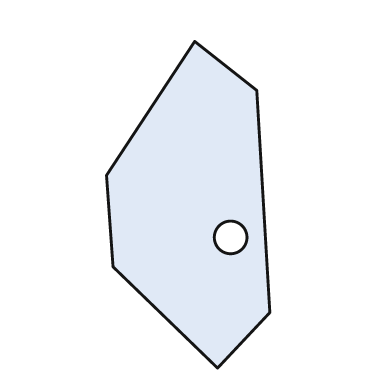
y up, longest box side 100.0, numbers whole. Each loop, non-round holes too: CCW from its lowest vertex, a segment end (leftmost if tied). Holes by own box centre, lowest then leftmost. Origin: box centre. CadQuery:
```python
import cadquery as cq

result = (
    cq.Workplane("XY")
    .moveTo(9.0, -50.0)
    .lineTo(25.0, -33.0)
    .lineTo(21.0, 35.0)
    .lineTo(2.0, 50.0)
    .lineTo(-25.0, 9.0)
    .lineTo(-23.0, -19.0)
    .close()
    .moveTo(13.0, -10.0)
    .circle(5.0)
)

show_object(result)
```